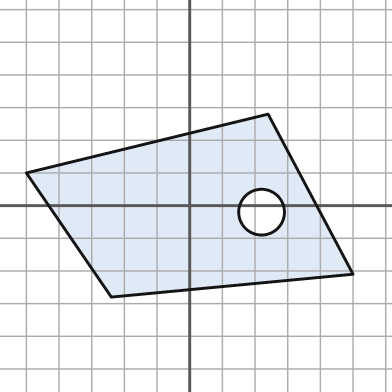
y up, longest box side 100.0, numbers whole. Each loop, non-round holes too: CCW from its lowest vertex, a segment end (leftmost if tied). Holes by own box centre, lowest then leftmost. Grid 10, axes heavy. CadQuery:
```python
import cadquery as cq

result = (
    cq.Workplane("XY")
    .moveTo(-24.0, -28.0)
    .lineTo(50.0, -21.0)
    .lineTo(24.0, 28.0)
    .lineTo(-50.0, 10.0)
    .close()
    .moveTo(22.0, -2.0)
    .circle(7.0)
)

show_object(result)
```